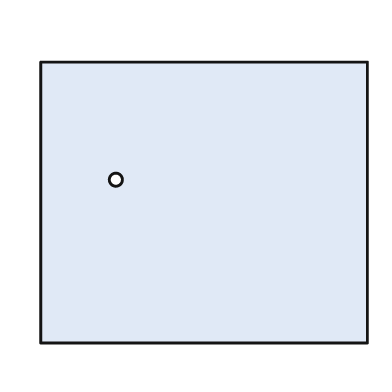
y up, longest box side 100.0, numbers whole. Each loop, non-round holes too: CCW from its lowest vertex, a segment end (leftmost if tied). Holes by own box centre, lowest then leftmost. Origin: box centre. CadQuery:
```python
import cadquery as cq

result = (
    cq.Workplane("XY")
    .moveTo(-50.0, -43.0)
    .lineTo(50.0, -43.0)
    .lineTo(50.0, 43.0)
    .lineTo(-50.0, 43.0)
    .close()
    .moveTo(-27.0, 7.0)
    .circle(2.0)
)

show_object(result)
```